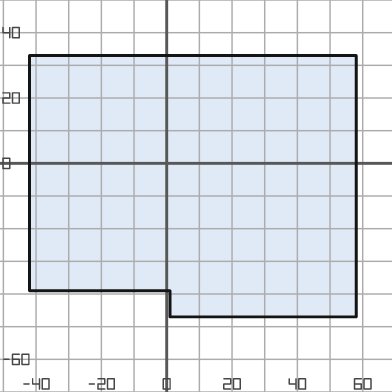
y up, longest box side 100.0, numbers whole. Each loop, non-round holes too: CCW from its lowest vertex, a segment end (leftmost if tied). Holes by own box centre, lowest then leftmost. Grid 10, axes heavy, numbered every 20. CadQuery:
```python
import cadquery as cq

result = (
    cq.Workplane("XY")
    .moveTo(1.0, -47.0)
    .lineTo(58.0, -47.0)
    .lineTo(58.0, 33.0)
    .lineTo(-42.0, 33.0)
    .lineTo(-42.0, -39.0)
    .lineTo(1.0, -39.0)
    .close()
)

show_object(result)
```